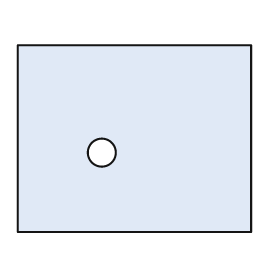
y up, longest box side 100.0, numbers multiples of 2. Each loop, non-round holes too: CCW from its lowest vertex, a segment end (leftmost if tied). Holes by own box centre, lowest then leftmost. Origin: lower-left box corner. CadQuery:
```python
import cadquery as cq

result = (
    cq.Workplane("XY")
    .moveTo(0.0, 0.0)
    .lineTo(100.0, 0.0)
    .lineTo(100.0, 80.0)
    .lineTo(0.0, 80.0)
    .close()
    .moveTo(36.0, 34.0)
    .circle(6.0)
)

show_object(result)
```